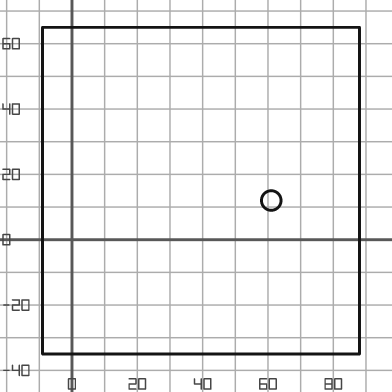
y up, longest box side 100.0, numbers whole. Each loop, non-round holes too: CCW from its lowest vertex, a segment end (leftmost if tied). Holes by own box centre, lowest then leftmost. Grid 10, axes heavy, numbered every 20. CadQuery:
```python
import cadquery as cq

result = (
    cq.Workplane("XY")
    .moveTo(-9.0, -35.0)
    .lineTo(88.0, -35.0)
    .lineTo(88.0, 65.0)
    .lineTo(-9.0, 65.0)
    .close()
    .moveTo(61.0, 12.0)
    .circle(3.0)
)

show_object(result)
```